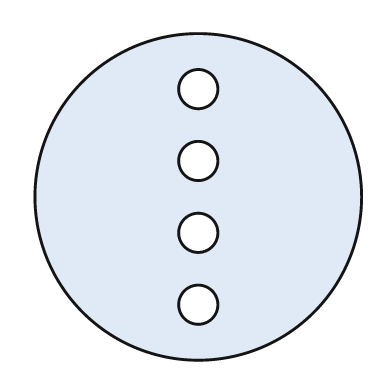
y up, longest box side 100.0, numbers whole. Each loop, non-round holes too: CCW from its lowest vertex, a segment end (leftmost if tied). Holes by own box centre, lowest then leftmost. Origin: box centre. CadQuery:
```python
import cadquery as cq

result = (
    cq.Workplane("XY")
    .moveTo(0.0, 0.0)
    .circle(50.0)
    .moveTo(0.0, -33.0)
    .circle(6.0)
    .moveTo(0.0, -11.0)
    .circle(6.0)
    .moveTo(0.0, 11.0)
    .circle(6.0)
    .moveTo(0.0, 33.0)
    .circle(6.0)
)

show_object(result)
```